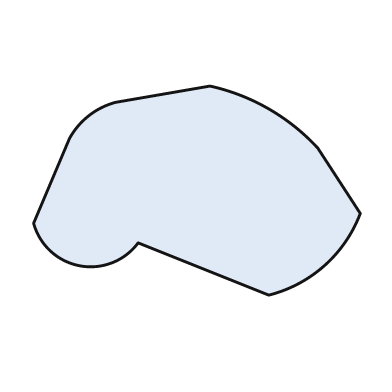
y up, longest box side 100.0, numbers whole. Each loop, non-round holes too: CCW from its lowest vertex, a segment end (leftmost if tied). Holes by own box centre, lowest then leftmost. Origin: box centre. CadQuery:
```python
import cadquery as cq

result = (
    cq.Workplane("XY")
    .moveTo(22.0, -32.0)
    .threePointArc((39.0, -23.0), (50.0, -7.0))
    .lineTo(37.0, 13.0)
    .threePointArc((22.0, 25.0), (4.0, 32.0))
    .lineTo(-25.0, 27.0)
    .threePointArc((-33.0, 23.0), (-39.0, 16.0))
    .lineTo(-50.0, -10.0)
    .threePointArc((-36.0, -23.0), (-18.0, -16.0))
    .close()
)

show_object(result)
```